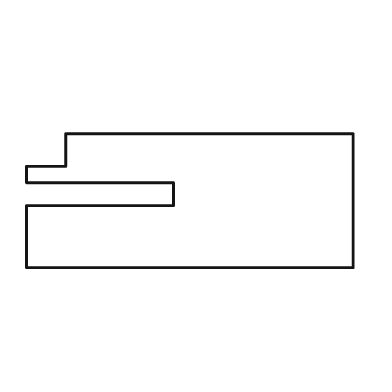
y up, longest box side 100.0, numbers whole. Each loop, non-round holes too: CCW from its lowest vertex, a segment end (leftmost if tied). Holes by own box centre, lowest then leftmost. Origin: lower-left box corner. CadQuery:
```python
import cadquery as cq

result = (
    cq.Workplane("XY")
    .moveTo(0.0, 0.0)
    .lineTo(100.0, 0.0)
    .lineTo(100.0, 41.0)
    .lineTo(12.0, 41.0)
    .lineTo(12.0, 31.0)
    .lineTo(0.0, 31.0)
    .lineTo(0.0, 26.0)
    .lineTo(45.0, 26.0)
    .lineTo(45.0, 19.0)
    .lineTo(0.0, 19.0)
    .close()
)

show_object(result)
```